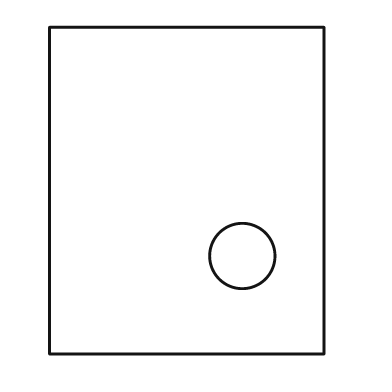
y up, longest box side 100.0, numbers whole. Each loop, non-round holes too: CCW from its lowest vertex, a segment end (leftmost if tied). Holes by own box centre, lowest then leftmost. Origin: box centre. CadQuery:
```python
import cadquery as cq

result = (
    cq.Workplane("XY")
    .moveTo(-42.0, -50.0)
    .lineTo(42.0, -50.0)
    .lineTo(42.0, 50.0)
    .lineTo(-42.0, 50.0)
    .close()
    .moveTo(17.0, -20.0)
    .circle(10.0)
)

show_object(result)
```